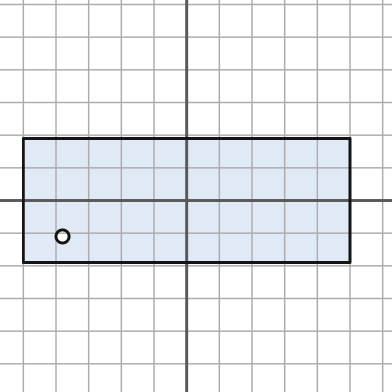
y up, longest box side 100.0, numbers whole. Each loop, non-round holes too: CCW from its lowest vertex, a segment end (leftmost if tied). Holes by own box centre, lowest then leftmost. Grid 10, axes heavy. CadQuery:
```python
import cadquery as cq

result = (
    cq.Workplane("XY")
    .moveTo(-50.0, -19.0)
    .lineTo(50.0, -19.0)
    .lineTo(50.0, 19.0)
    .lineTo(-50.0, 19.0)
    .close()
    .moveTo(-38.0, -11.0)
    .circle(2.0)
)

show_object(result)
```